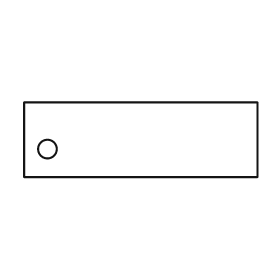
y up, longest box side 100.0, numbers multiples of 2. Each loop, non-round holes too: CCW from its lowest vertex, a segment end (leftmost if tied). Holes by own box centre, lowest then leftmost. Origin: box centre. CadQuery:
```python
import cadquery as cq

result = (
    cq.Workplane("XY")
    .moveTo(-50.0, -16.0)
    .lineTo(50.0, -16.0)
    .lineTo(50.0, 16.0)
    .lineTo(-50.0, 16.0)
    .close()
    .moveTo(-40.0, -4.0)
    .circle(4.0)
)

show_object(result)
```